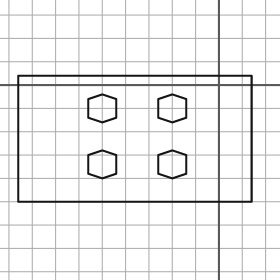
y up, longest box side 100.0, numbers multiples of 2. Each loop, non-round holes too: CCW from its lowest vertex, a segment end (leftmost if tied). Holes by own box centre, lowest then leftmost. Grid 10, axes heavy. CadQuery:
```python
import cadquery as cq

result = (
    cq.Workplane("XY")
    .moveTo(-86.0, -50.0)
    .lineTo(14.0, -50.0)
    .lineTo(14.0, 4.0)
    .lineTo(-86.0, 4.0)
    .close()
    .moveTo(-50.0, -40.0)
    .lineTo(-44.0, -38.0)
    .lineTo(-44.0, -30.0)
    .lineTo(-50.0, -28.0)
    .lineTo(-56.0, -30.0)
    .lineTo(-56.0, -38.0)
    .close()
    .moveTo(-20.0, -40.0)
    .lineTo(-14.0, -38.0)
    .lineTo(-14.0, -30.0)
    .lineTo(-20.0, -28.0)
    .lineTo(-26.0, -30.0)
    .lineTo(-26.0, -38.0)
    .close()
    .moveTo(-50.0, -16.0)
    .lineTo(-44.0, -14.0)
    .lineTo(-44.0, -6.0)
    .lineTo(-50.0, -4.0)
    .lineTo(-56.0, -6.0)
    .lineTo(-56.0, -14.0)
    .close()
    .moveTo(-20.0, -16.0)
    .lineTo(-14.0, -14.0)
    .lineTo(-14.0, -6.0)
    .lineTo(-20.0, -4.0)
    .lineTo(-26.0, -6.0)
    .lineTo(-26.0, -14.0)
    .close()
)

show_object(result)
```